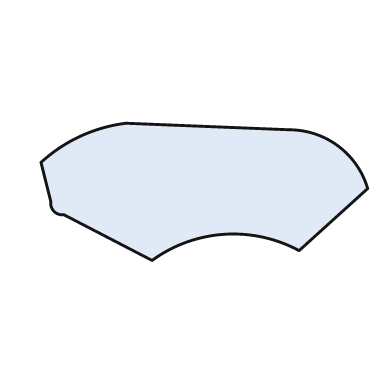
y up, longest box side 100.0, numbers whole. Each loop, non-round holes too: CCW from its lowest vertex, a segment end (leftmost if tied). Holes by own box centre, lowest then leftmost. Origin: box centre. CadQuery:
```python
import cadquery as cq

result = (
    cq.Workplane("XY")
    .moveTo(-16.0, -21.0)
    .threePointArc((6.0, -13.0), (29.0, -18.0))
    .lineTo(50.0, 1.0)
    .threePointArc((41.0, 14.0), (26.0, 19.0))
    .lineTo(-24.0, 21.0)
    .threePointArc((-38.0, 17.0), (-50.0, 9.0))
    .lineTo(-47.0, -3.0)
    .threePointArc((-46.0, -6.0), (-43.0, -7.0))
    .close()
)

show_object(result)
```